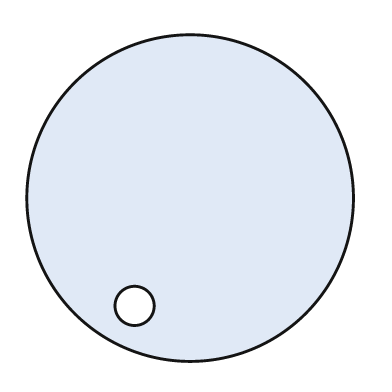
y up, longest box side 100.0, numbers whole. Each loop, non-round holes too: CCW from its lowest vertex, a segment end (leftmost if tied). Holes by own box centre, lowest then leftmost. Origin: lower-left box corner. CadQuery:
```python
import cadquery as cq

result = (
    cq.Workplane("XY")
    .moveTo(50.0, 50.0)
    .circle(50.0)
    .moveTo(33.0, 17.0)
    .circle(6.0)
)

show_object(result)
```